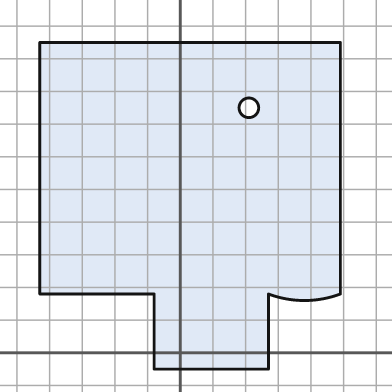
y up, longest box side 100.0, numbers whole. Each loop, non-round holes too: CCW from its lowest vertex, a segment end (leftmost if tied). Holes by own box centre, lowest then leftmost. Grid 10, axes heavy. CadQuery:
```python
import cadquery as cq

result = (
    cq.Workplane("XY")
    .moveTo(-8.0, -5.0)
    .lineTo(27.0, -5.0)
    .lineTo(27.0, 18.0)
    .threePointArc((38.0, 16.0), (49.0, 18.0))
    .lineTo(49.0, 95.0)
    .lineTo(-43.0, 95.0)
    .lineTo(-43.0, 18.0)
    .lineTo(-8.0, 18.0)
    .close()
    .moveTo(21.0, 75.0)
    .circle(3.0)
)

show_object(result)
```